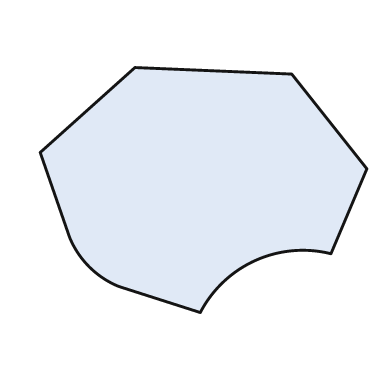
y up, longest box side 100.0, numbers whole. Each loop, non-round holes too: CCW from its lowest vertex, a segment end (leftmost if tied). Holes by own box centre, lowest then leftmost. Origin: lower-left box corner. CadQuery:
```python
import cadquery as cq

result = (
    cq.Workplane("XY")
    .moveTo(49.0, 0.0)
    .threePointArc((66.0, 16.0), (89.0, 18.0))
    .lineTo(100.0, 44.0)
    .lineTo(77.0, 73.0)
    .lineTo(29.0, 75.0)
    .lineTo(0.0, 49.0)
    .lineTo(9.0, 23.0)
    .threePointArc((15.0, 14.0), (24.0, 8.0))
    .close()
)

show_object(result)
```